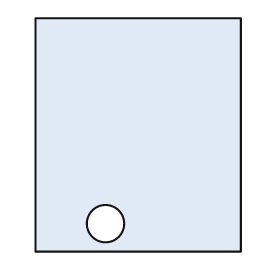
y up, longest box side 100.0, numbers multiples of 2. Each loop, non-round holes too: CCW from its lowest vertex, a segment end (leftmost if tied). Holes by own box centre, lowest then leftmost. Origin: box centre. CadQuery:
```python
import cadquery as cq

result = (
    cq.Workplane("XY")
    .moveTo(-44.0, -50.0)
    .lineTo(44.0, -50.0)
    .lineTo(44.0, 50.0)
    .lineTo(-44.0, 50.0)
    .close()
    .moveTo(-14.0, -38.0)
    .circle(8.0)
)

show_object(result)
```